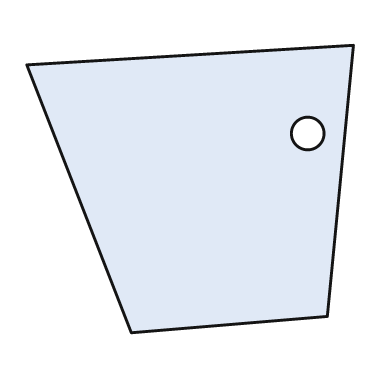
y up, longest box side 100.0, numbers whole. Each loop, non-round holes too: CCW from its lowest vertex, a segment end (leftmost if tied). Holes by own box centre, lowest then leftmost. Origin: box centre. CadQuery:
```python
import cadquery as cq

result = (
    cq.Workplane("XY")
    .moveTo(-18.0, -44.0)
    .lineTo(42.0, -39.0)
    .lineTo(50.0, 44.0)
    .lineTo(-50.0, 38.0)
    .close()
    .moveTo(36.0, 17.0)
    .circle(5.0)
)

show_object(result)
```